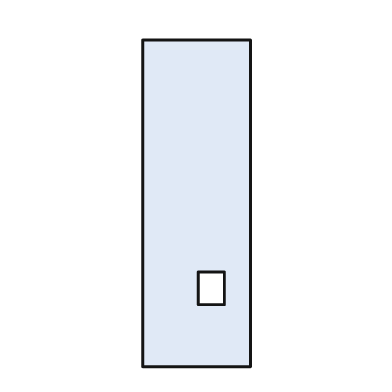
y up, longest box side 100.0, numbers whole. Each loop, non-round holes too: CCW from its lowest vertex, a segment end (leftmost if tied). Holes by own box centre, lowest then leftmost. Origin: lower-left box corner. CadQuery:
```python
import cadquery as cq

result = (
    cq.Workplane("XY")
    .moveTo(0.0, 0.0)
    .lineTo(33.0, 0.0)
    .lineTo(33.0, 100.0)
    .lineTo(0.0, 100.0)
    .close()
    .moveTo(17.0, 19.0)
    .lineTo(25.0, 19.0)
    .lineTo(25.0, 29.0)
    .lineTo(17.0, 29.0)
    .close()
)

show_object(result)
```